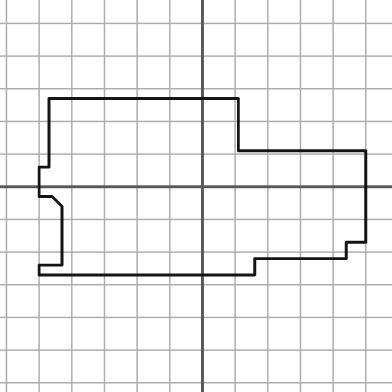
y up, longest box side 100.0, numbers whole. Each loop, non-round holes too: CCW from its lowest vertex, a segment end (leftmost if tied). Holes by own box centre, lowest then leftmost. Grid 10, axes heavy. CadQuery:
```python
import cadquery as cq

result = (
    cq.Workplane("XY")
    .moveTo(-50.0, -27.0)
    .lineTo(16.0, -27.0)
    .lineTo(16.0, -22.0)
    .lineTo(44.0, -22.0)
    .lineTo(44.0, -17.0)
    .lineTo(50.0, -17.0)
    .lineTo(50.0, 11.0)
    .lineTo(11.0, 11.0)
    .lineTo(11.0, 27.0)
    .lineTo(-47.0, 27.0)
    .lineTo(-47.0, 6.0)
    .lineTo(-50.0, 6.0)
    .lineTo(-50.0, -3.0)
    .lineTo(-46.0, -3.0)
    .lineTo(-43.0, -6.0)
    .lineTo(-43.0, -24.0)
    .lineTo(-50.0, -24.0)
    .close()
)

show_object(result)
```